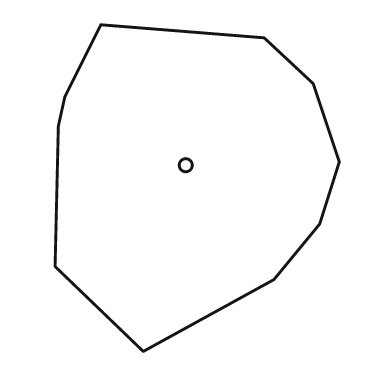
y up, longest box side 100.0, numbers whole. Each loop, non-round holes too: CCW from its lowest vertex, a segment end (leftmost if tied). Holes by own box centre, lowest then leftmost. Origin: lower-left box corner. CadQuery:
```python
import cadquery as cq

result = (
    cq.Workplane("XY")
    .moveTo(27.0, 0.0)
    .lineTo(67.0, 22.0)
    .lineTo(81.0, 39.0)
    .lineTo(87.0, 58.0)
    .lineTo(79.0, 82.0)
    .lineTo(64.0, 96.0)
    .lineTo(14.0, 100.0)
    .lineTo(3.0, 78.0)
    .lineTo(1.0, 69.0)
    .lineTo(0.0, 26.0)
    .close()
    .moveTo(40.0, 57.0)
    .circle(2.0)
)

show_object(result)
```